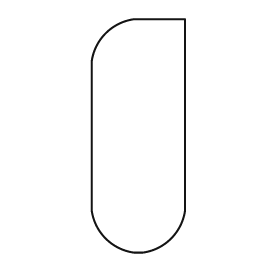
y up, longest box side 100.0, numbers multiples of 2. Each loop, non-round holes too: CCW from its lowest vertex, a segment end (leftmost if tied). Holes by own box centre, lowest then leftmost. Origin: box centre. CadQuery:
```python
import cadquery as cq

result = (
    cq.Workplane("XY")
    .moveTo(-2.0, -50.0)
    .lineTo(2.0, -50.0)
    .threePointArc((14.0, -44.0), (20.0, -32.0))
    .lineTo(20.0, 50.0)
    .lineTo(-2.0, 50.0)
    .threePointArc((-14.0, 44.0), (-20.0, 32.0))
    .lineTo(-20.0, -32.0)
    .threePointArc((-14.0, -44.0), (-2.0, -50.0))
    .close()
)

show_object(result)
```